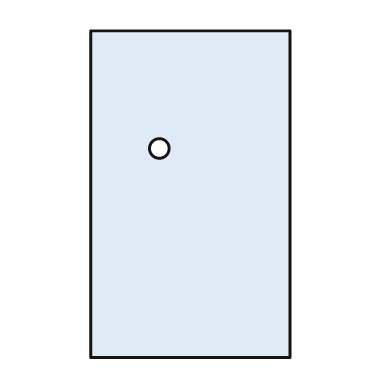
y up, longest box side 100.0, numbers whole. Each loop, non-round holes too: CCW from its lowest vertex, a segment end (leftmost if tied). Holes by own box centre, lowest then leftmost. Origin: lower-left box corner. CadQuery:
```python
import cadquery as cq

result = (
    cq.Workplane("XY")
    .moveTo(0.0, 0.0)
    .lineTo(61.0, 0.0)
    .lineTo(61.0, 100.0)
    .lineTo(0.0, 100.0)
    .close()
    .moveTo(21.0, 64.0)
    .circle(3.0)
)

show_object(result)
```